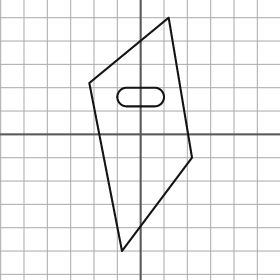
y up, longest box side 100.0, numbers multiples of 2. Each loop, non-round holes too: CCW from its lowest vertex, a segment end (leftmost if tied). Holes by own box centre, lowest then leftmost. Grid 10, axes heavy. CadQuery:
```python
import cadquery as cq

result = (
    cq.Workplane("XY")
    .moveTo(-8.0, -50.0)
    .lineTo(22.0, -10.0)
    .lineTo(12.0, 50.0)
    .lineTo(-22.0, 22.0)
    .close()
    .moveTo(-6.0, 12.0)
    .lineTo(6.0, 12.0)
    .threePointArc((10.0, 16.0), (6.0, 20.0))
    .lineTo(-6.0, 20.0)
    .threePointArc((-10.0, 16.0), (-6.0, 12.0))
    .close()
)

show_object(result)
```